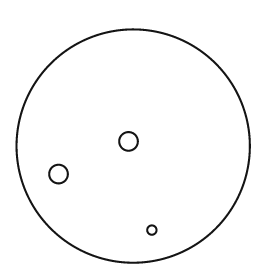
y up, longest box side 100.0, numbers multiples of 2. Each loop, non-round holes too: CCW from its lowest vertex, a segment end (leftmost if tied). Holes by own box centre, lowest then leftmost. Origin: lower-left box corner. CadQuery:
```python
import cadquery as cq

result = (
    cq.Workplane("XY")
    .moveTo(50.0, 50.0)
    .circle(50.0)
    .moveTo(58.0, 14.0)
    .circle(2.0)
    .moveTo(18.0, 38.0)
    .circle(4.0)
    .moveTo(48.0, 52.0)
    .circle(4.0)
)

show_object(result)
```